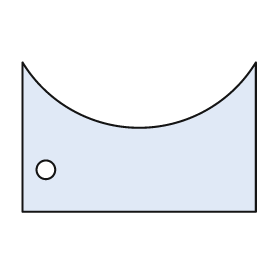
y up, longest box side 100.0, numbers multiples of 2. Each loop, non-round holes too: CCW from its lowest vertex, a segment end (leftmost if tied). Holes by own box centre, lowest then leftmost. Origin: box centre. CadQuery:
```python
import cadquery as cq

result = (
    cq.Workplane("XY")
    .moveTo(-50.0, -32.0)
    .lineTo(50.0, -32.0)
    .lineTo(50.0, 32.0)
    .threePointArc((0.0, 4.0), (-50.0, 32.0))
    .close()
    .moveTo(-40.0, -14.0)
    .circle(4.0)
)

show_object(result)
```